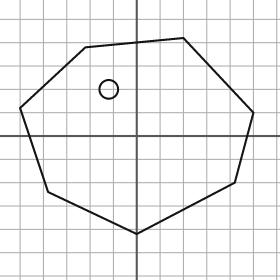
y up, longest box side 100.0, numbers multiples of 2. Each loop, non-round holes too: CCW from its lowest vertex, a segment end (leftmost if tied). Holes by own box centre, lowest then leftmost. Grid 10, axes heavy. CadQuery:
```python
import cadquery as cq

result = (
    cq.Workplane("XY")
    .moveTo(0.0, -42.0)
    .lineTo(42.0, -20.0)
    .lineTo(50.0, 10.0)
    .lineTo(20.0, 42.0)
    .lineTo(-22.0, 38.0)
    .lineTo(-50.0, 12.0)
    .lineTo(-38.0, -24.0)
    .close()
    .moveTo(-12.0, 20.0)
    .circle(4.0)
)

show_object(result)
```